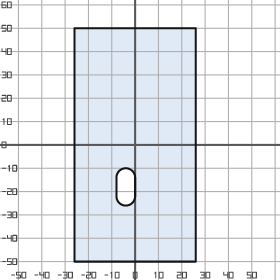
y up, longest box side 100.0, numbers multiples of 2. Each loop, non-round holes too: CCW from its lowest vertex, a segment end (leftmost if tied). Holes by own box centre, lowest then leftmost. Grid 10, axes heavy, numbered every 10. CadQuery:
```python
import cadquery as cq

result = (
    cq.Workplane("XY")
    .moveTo(-26.0, -50.0)
    .lineTo(26.0, -50.0)
    .lineTo(26.0, 50.0)
    .lineTo(-26.0, 50.0)
    .close()
    .moveTo(-8.0, -22.0)
    .threePointArc((-4.0, -26.0), (0.0, -22.0))
    .lineTo(0.0, -14.0)
    .threePointArc((-4.0, -10.0), (-8.0, -14.0))
    .close()
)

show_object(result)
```